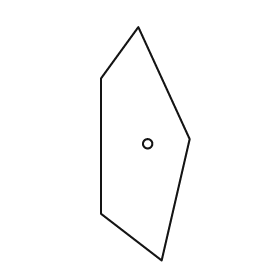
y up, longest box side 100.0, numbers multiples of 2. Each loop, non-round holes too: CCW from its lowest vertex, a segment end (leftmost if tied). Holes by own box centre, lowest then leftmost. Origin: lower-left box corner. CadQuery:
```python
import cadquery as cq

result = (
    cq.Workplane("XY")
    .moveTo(26.0, 0.0)
    .lineTo(38.0, 52.0)
    .lineTo(16.0, 100.0)
    .lineTo(0.0, 78.0)
    .lineTo(0.0, 20.0)
    .close()
    .moveTo(20.0, 50.0)
    .circle(2.0)
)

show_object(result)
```